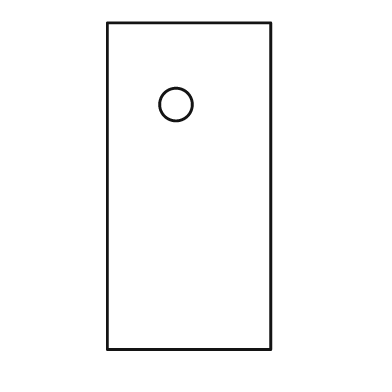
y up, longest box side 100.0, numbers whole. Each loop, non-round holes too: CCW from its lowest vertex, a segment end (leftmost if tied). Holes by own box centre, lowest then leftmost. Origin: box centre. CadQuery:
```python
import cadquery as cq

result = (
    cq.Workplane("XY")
    .moveTo(-25.0, -50.0)
    .lineTo(25.0, -50.0)
    .lineTo(25.0, 50.0)
    .lineTo(-25.0, 50.0)
    .close()
    .moveTo(-4.0, 25.0)
    .circle(5.0)
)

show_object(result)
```